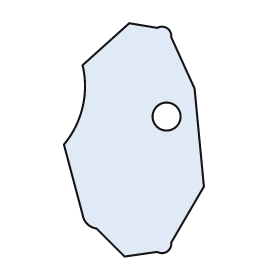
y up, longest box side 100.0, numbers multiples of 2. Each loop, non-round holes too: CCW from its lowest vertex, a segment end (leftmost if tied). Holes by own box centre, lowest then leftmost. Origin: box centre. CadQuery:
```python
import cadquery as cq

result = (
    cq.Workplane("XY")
    .moveTo(-4.0, -50.0)
    .lineTo(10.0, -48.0)
    .threePointArc((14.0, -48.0), (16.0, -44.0))
    .lineTo(30.0, -20.0)
    .lineTo(26.0, 22.0)
    .lineTo(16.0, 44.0)
    .threePointArc((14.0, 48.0), (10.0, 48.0))
    .lineTo(-2.0, 50.0)
    .lineTo(-22.0, 32.0)
    .threePointArc((-22.0, 14.0), (-30.0, -2.0))
    .lineTo(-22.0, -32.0)
    .threePointArc((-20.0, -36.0), (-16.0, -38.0))
    .close()
    .moveTo(14.0, 10.0)
    .circle(6.0)
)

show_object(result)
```